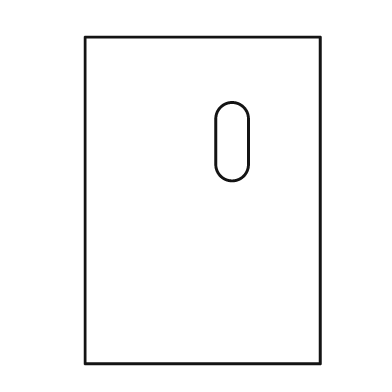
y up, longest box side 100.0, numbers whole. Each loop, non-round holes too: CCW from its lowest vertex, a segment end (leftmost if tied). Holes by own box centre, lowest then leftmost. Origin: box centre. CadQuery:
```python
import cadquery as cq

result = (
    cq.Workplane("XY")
    .moveTo(-36.0, -50.0)
    .lineTo(36.0, -50.0)
    .lineTo(36.0, 50.0)
    .lineTo(-36.0, 50.0)
    .close()
    .moveTo(4.0, 11.0)
    .threePointArc((9.0, 6.0), (14.0, 11.0))
    .lineTo(14.0, 25.0)
    .threePointArc((9.0, 30.0), (4.0, 25.0))
    .close()
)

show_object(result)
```